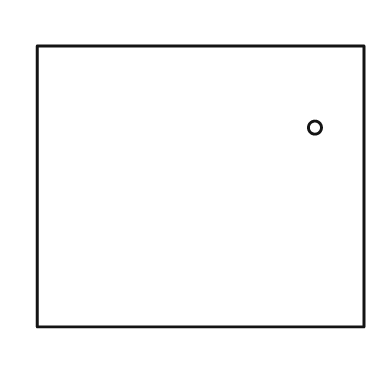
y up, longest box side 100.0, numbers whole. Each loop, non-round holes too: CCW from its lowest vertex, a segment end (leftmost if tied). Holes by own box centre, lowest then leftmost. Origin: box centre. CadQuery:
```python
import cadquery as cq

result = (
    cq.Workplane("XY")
    .moveTo(-50.0, -43.0)
    .lineTo(50.0, -43.0)
    .lineTo(50.0, 43.0)
    .lineTo(-50.0, 43.0)
    .close()
    .moveTo(35.0, 18.0)
    .circle(2.0)
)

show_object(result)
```